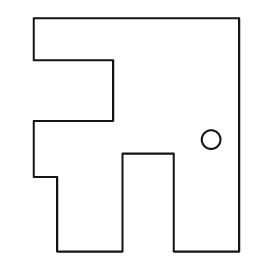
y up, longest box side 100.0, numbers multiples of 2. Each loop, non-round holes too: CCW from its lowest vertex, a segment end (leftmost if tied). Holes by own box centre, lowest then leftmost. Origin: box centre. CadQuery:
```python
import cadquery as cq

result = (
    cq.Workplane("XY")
    .moveTo(-34.0, -50.0)
    .lineTo(-6.0, -50.0)
    .lineTo(-6.0, -8.0)
    .lineTo(16.0, -8.0)
    .lineTo(16.0, -50.0)
    .lineTo(44.0, -50.0)
    .lineTo(44.0, 50.0)
    .lineTo(-44.0, 50.0)
    .lineTo(-44.0, 32.0)
    .lineTo(-10.0, 32.0)
    .lineTo(-10.0, 6.0)
    .lineTo(-44.0, 6.0)
    .lineTo(-44.0, -18.0)
    .lineTo(-34.0, -18.0)
    .close()
    .moveTo(32.0, -2.0)
    .circle(4.0)
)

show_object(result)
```